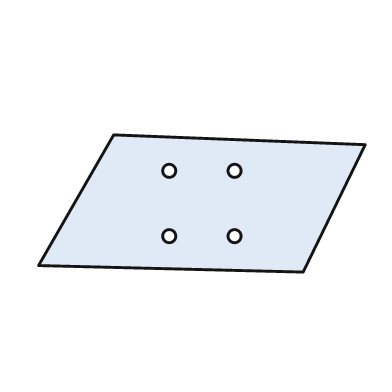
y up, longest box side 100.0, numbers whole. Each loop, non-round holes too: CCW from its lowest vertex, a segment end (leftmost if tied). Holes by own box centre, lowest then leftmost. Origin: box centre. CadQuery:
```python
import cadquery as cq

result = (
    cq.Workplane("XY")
    .moveTo(31.0, -21.0)
    .lineTo(50.0, 18.0)
    .lineTo(-27.0, 21.0)
    .lineTo(-50.0, -19.0)
    .close()
    .moveTo(-10.0, -10.0)
    .circle(2.0)
    .moveTo(10.0, -10.0)
    .circle(2.0)
    .moveTo(-10.0, 10.0)
    .circle(2.0)
    .moveTo(10.0, 10.0)
    .circle(2.0)
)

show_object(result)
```